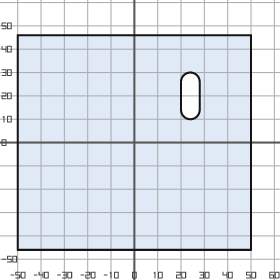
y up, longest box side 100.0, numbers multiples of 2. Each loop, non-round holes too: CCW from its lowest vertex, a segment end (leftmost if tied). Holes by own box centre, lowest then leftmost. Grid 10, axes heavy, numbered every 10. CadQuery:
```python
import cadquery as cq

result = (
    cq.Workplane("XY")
    .moveTo(-50.0, -46.0)
    .lineTo(50.0, -46.0)
    .lineTo(50.0, 46.0)
    .lineTo(-50.0, 46.0)
    .close()
    .moveTo(20.0, 14.0)
    .threePointArc((24.0, 10.0), (28.0, 14.0))
    .lineTo(28.0, 26.0)
    .threePointArc((24.0, 30.0), (20.0, 26.0))
    .close()
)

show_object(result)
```